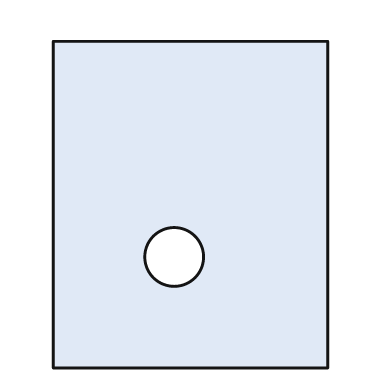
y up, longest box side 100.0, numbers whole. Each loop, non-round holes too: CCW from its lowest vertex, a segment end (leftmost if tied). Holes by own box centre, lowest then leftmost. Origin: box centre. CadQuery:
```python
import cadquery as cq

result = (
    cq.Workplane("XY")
    .moveTo(-42.0, -50.0)
    .lineTo(42.0, -50.0)
    .lineTo(42.0, 50.0)
    .lineTo(-42.0, 50.0)
    .close()
    .moveTo(-5.0, -16.0)
    .circle(9.0)
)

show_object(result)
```